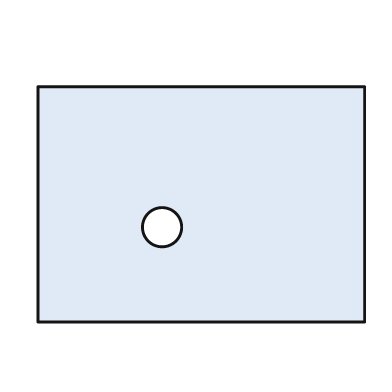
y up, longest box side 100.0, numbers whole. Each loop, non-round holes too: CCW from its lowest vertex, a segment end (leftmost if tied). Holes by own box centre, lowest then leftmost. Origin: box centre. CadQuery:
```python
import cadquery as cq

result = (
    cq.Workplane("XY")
    .moveTo(-50.0, -36.0)
    .lineTo(50.0, -36.0)
    .lineTo(50.0, 36.0)
    .lineTo(-50.0, 36.0)
    .close()
    .moveTo(-12.0, -7.0)
    .circle(6.0)
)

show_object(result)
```